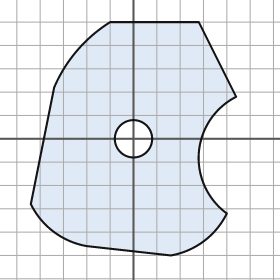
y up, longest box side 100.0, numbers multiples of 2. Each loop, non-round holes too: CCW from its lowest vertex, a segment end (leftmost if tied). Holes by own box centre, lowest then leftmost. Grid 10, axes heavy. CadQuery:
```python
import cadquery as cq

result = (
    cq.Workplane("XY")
    .moveTo(16.0, -50.0)
    .threePointArc((30.0, -44.0), (40.0, -32.0))
    .threePointArc((28.0, -6.0), (44.0, 18.0))
    .lineTo(28.0, 50.0)
    .lineTo(-10.0, 50.0)
    .threePointArc((-24.0, 38.0), (-34.0, 22.0))
    .lineTo(-44.0, -28.0)
    .threePointArc((-34.0, -40.0), (-20.0, -46.0))
    .close()
    .moveTo(0.0, 0.0)
    .circle(8.0)
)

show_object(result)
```